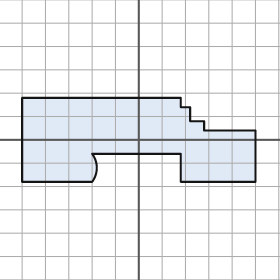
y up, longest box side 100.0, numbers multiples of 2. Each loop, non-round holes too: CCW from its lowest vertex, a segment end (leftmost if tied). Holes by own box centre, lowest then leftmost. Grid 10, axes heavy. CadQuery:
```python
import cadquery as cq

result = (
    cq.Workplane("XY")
    .moveTo(-50.0, -18.0)
    .lineTo(-20.0, -18.0)
    .threePointArc((-18.0, -12.0), (-20.0, -6.0))
    .lineTo(18.0, -6.0)
    .lineTo(18.0, -18.0)
    .lineTo(50.0, -18.0)
    .lineTo(50.0, 4.0)
    .lineTo(28.0, 4.0)
    .lineTo(28.0, 8.0)
    .lineTo(22.0, 8.0)
    .lineTo(22.0, 14.0)
    .lineTo(18.0, 14.0)
    .lineTo(18.0, 18.0)
    .lineTo(-50.0, 18.0)
    .close()
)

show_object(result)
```